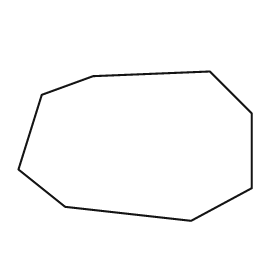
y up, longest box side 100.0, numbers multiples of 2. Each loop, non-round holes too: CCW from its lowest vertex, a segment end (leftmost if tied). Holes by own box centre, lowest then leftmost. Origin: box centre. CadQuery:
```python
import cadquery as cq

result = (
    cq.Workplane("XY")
    .moveTo(24.0, -32.0)
    .lineTo(50.0, -18.0)
    .lineTo(50.0, 14.0)
    .lineTo(32.0, 32.0)
    .lineTo(-18.0, 30.0)
    .lineTo(-40.0, 22.0)
    .lineTo(-50.0, -10.0)
    .lineTo(-30.0, -26.0)
    .close()
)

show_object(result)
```